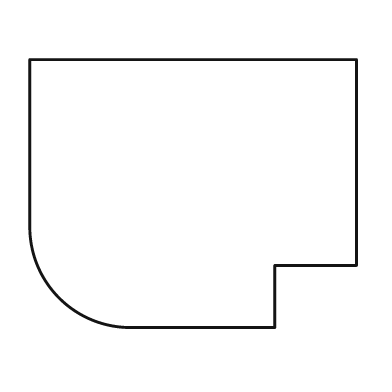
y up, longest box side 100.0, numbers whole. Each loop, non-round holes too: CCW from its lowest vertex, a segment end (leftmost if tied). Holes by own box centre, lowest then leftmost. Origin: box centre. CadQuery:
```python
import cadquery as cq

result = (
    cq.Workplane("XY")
    .moveTo(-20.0, -41.0)
    .lineTo(25.0, -41.0)
    .lineTo(25.0, -22.0)
    .lineTo(50.0, -22.0)
    .lineTo(50.0, 41.0)
    .lineTo(-50.0, 41.0)
    .lineTo(-50.0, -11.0)
    .threePointArc((-41.0, -32.0), (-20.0, -41.0))
    .close()
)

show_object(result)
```